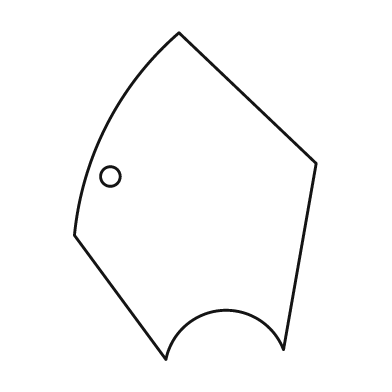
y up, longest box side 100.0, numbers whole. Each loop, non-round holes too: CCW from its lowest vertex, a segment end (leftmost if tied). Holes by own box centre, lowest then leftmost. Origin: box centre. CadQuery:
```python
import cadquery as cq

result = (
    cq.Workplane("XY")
    .moveTo(-9.0, -50.0)
    .threePointArc((8.0, -35.0), (27.0, -47.0))
    .lineTo(37.0, 10.0)
    .lineTo(-5.0, 50.0)
    .threePointArc((-27.0, 22.0), (-37.0, -12.0))
    .close()
    .moveTo(-26.0, 6.0)
    .circle(3.0)
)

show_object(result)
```